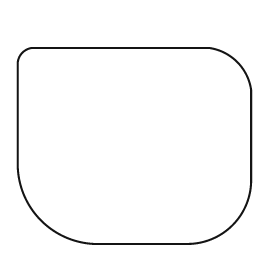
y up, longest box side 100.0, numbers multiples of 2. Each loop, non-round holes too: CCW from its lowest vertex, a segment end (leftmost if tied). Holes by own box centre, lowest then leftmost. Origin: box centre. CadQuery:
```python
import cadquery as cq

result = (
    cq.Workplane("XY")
    .moveTo(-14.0, -42.0)
    .lineTo(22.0, -42.0)
    .threePointArc((42.0, -34.0), (50.0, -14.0))
    .lineTo(50.0, 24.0)
    .threePointArc((44.0, 36.0), (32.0, 42.0))
    .lineTo(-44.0, 42.0)
    .threePointArc((-48.0, 40.0), (-50.0, 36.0))
    .lineTo(-50.0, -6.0)
    .threePointArc((-40.0, -32.0), (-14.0, -42.0))
    .close()
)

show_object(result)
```